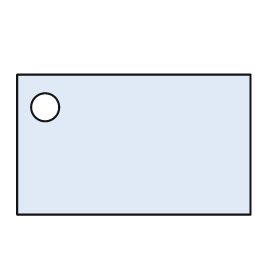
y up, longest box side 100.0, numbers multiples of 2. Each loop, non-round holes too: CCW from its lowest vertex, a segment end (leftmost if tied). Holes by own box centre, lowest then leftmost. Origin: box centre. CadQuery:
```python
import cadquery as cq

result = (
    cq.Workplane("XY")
    .moveTo(-50.0, -30.0)
    .lineTo(50.0, -30.0)
    .lineTo(50.0, 30.0)
    .lineTo(-50.0, 30.0)
    .close()
    .moveTo(-38.0, 16.0)
    .circle(6.0)
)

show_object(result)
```